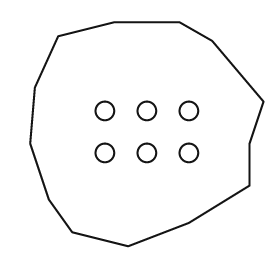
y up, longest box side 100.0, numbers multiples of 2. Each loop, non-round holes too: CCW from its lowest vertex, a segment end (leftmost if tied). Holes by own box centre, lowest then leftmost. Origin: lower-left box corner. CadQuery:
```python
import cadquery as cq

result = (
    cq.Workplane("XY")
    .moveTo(42.0, 0.0)
    .lineTo(68.0, 10.0)
    .lineTo(94.0, 26.0)
    .lineTo(94.0, 44.0)
    .lineTo(100.0, 62.0)
    .lineTo(78.0, 88.0)
    .lineTo(64.0, 96.0)
    .lineTo(36.0, 96.0)
    .lineTo(12.0, 90.0)
    .lineTo(2.0, 68.0)
    .lineTo(0.0, 44.0)
    .lineTo(8.0, 20.0)
    .lineTo(18.0, 6.0)
    .close()
    .moveTo(32.0, 40.0)
    .circle(4.0)
    .moveTo(50.0, 40.0)
    .circle(4.0)
    .moveTo(68.0, 40.0)
    .circle(4.0)
    .moveTo(32.0, 58.0)
    .circle(4.0)
    .moveTo(50.0, 58.0)
    .circle(4.0)
    .moveTo(68.0, 58.0)
    .circle(4.0)
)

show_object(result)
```